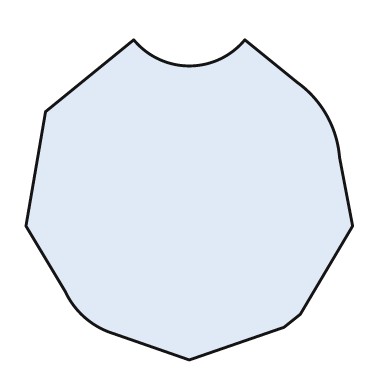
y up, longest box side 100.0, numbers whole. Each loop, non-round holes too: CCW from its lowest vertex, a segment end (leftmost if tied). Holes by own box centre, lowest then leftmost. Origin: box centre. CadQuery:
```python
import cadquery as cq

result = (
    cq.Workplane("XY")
    .moveTo(0.0, -49.0)
    .lineTo(29.0, -39.0)
    .lineTo(34.0, -35.0)
    .lineTo(50.0, -8.0)
    .lineTo(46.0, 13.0)
    .threePointArc((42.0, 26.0), (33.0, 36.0))
    .lineTo(17.0, 49.0)
    .threePointArc((0.0, 41.0), (-17.0, 49.0))
    .lineTo(-44.0, 27.0)
    .lineTo(-50.0, -8.0)
    .lineTo(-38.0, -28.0)
    .threePointArc((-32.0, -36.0), (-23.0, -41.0))
    .close()
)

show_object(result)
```